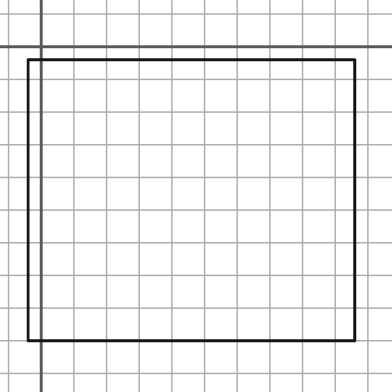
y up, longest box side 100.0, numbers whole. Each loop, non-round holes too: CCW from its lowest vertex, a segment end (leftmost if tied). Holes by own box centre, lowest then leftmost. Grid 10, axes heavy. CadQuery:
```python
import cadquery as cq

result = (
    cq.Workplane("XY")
    .moveTo(-4.0, -90.0)
    .lineTo(96.0, -90.0)
    .lineTo(96.0, -4.0)
    .lineTo(-4.0, -4.0)
    .close()
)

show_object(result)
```